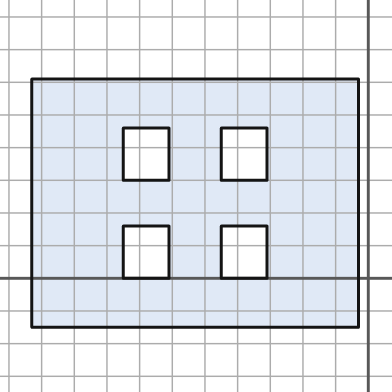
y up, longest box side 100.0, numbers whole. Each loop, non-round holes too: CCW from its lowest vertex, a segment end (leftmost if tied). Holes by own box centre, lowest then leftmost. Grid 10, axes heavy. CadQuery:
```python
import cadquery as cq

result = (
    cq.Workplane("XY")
    .moveTo(-103.0, -15.0)
    .lineTo(-3.0, -15.0)
    .lineTo(-3.0, 61.0)
    .lineTo(-103.0, 61.0)
    .close()
    .moveTo(-75.0, 0.0)
    .lineTo(-61.0, 0.0)
    .lineTo(-61.0, 16.0)
    .lineTo(-75.0, 16.0)
    .close()
    .moveTo(-45.0, 0.0)
    .lineTo(-31.0, 0.0)
    .lineTo(-31.0, 16.0)
    .lineTo(-45.0, 16.0)
    .close()
    .moveTo(-75.0, 30.0)
    .lineTo(-61.0, 30.0)
    .lineTo(-61.0, 46.0)
    .lineTo(-75.0, 46.0)
    .close()
    .moveTo(-45.0, 30.0)
    .lineTo(-31.0, 30.0)
    .lineTo(-31.0, 46.0)
    .lineTo(-45.0, 46.0)
    .close()
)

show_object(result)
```